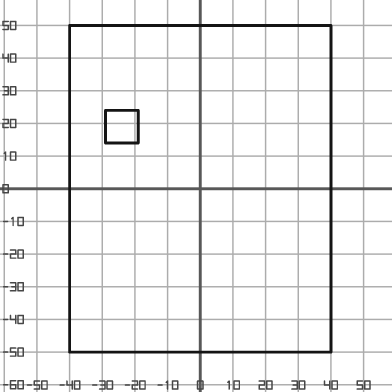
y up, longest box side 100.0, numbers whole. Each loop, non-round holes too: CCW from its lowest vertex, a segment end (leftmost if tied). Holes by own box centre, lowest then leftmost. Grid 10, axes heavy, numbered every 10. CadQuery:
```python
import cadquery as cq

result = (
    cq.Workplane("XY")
    .moveTo(-40.0, -50.0)
    .lineTo(40.0, -50.0)
    .lineTo(40.0, 50.0)
    .lineTo(-40.0, 50.0)
    .close()
    .moveTo(-29.0, 14.0)
    .lineTo(-19.0, 14.0)
    .lineTo(-19.0, 24.0)
    .lineTo(-29.0, 24.0)
    .close()
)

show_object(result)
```